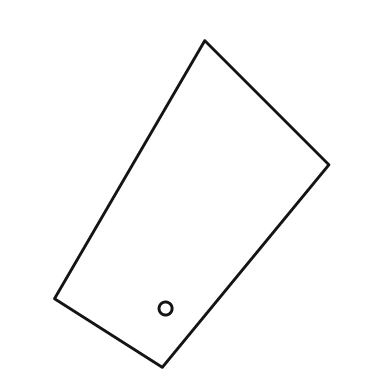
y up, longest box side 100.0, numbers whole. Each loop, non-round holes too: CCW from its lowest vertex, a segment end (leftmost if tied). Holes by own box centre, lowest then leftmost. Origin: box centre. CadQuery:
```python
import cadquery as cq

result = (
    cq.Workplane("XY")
    .moveTo(-9.0, -50.0)
    .lineTo(42.0, 12.0)
    .lineTo(4.0, 50.0)
    .lineTo(-42.0, -29.0)
    .close()
    .moveTo(-8.0, -32.0)
    .circle(2.0)
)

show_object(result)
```